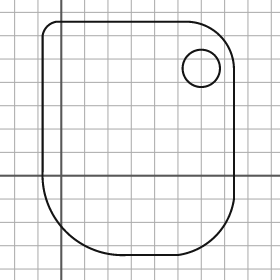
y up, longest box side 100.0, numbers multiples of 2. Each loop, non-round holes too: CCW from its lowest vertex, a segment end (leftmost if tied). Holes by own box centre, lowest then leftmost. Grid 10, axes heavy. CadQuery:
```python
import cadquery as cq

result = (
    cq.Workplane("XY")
    .moveTo(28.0, -34.0)
    .lineTo(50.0, -34.0)
    .threePointArc((66.0, -26.0), (74.0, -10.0))
    .lineTo(74.0, 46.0)
    .threePointArc((68.0, 60.0), (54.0, 66.0))
    .lineTo(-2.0, 66.0)
    .threePointArc((-6.0, 64.0), (-8.0, 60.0))
    .lineTo(-8.0, 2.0)
    .threePointArc((2.0, -24.0), (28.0, -34.0))
    .close()
    .moveTo(60.0, 46.0)
    .circle(8.0)
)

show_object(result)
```